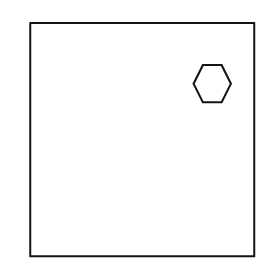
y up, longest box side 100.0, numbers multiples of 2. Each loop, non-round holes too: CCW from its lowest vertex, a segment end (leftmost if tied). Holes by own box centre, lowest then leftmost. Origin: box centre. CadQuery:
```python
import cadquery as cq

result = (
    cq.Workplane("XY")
    .moveTo(-48.0, -50.0)
    .lineTo(48.0, -50.0)
    .lineTo(48.0, 50.0)
    .lineTo(-48.0, 50.0)
    .close()
    .moveTo(26.0, 16.0)
    .lineTo(34.0, 16.0)
    .lineTo(38.0, 24.0)
    .lineTo(34.0, 32.0)
    .lineTo(26.0, 32.0)
    .lineTo(22.0, 24.0)
    .close()
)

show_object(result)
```